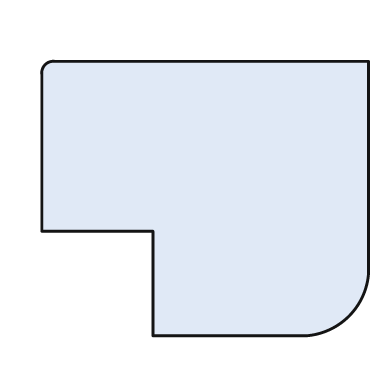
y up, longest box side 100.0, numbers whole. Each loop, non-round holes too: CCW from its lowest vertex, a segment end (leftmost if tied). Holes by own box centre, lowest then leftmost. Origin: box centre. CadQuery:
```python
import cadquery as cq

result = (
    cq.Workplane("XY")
    .moveTo(-16.0, -42.0)
    .lineTo(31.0, -42.0)
    .threePointArc((44.0, -36.0), (50.0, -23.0))
    .lineTo(50.0, 42.0)
    .lineTo(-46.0, 42.0)
    .threePointArc((-49.0, 41.0), (-50.0, 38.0))
    .lineTo(-50.0, -10.0)
    .lineTo(-16.0, -10.0)
    .close()
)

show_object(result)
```